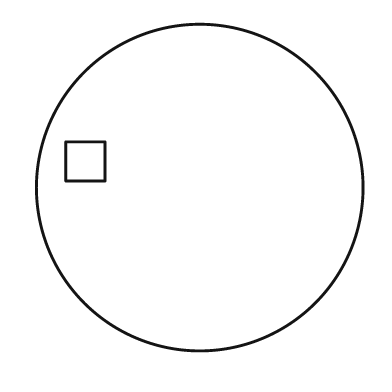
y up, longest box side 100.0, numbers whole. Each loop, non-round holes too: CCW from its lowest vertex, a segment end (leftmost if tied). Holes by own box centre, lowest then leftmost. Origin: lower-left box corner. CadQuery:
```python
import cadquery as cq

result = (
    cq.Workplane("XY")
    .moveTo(50.0, 50.0)
    .circle(50.0)
    .moveTo(9.0, 52.0)
    .lineTo(21.0, 52.0)
    .lineTo(21.0, 64.0)
    .lineTo(9.0, 64.0)
    .close()
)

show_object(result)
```